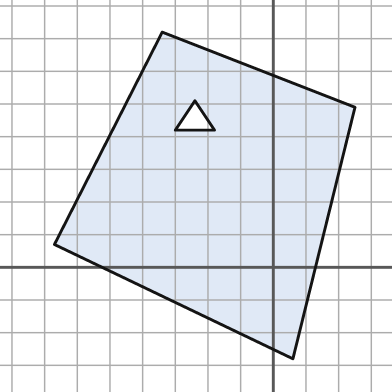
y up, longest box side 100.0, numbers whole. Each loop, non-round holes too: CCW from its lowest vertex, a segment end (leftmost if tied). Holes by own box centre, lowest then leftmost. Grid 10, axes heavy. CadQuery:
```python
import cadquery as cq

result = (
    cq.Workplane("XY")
    .moveTo(6.0, -28.0)
    .lineTo(25.0, 49.0)
    .lineTo(-34.0, 72.0)
    .lineTo(-67.0, 7.0)
    .close()
    .moveTo(-30.0, 42.0)
    .lineTo(-18.0, 42.0)
    .lineTo(-24.0, 51.0)
    .close()
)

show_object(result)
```